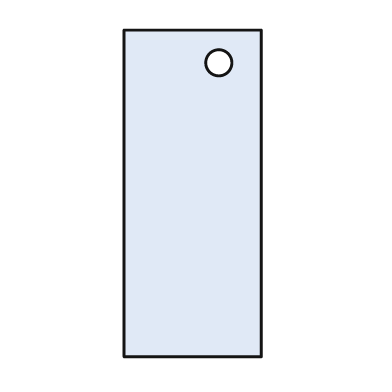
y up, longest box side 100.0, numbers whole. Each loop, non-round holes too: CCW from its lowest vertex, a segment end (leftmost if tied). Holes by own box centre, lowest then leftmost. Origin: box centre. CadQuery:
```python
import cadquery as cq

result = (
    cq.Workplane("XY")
    .moveTo(-21.0, -50.0)
    .lineTo(21.0, -50.0)
    .lineTo(21.0, 50.0)
    .lineTo(-21.0, 50.0)
    .close()
    .moveTo(8.0, 40.0)
    .circle(4.0)
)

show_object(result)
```